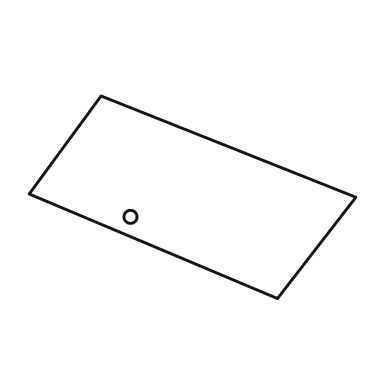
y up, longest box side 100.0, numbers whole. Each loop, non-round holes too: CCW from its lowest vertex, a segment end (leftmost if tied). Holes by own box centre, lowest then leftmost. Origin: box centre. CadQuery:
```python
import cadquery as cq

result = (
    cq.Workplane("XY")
    .moveTo(26.0, -31.0)
    .lineTo(50.0, 0.0)
    .lineTo(-28.0, 31.0)
    .lineTo(-50.0, 1.0)
    .close()
    .moveTo(-19.0, -6.0)
    .circle(2.0)
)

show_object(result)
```